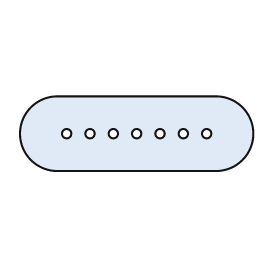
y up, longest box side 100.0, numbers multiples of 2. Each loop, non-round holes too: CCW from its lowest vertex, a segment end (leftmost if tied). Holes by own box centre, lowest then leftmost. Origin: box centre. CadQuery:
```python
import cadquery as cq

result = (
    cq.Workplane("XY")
    .moveTo(-34.0, -16.0)
    .lineTo(34.0, -16.0)
    .threePointArc((50.0, 0.0), (34.0, 16.0))
    .lineTo(-34.0, 16.0)
    .threePointArc((-50.0, 0.0), (-34.0, -16.0))
    .close()
    .moveTo(-30.0, 0.0)
    .circle(2.0)
    .moveTo(-20.0, 0.0)
    .circle(2.0)
    .moveTo(-10.0, 0.0)
    .circle(2.0)
    .moveTo(0.0, 0.0)
    .circle(2.0)
    .moveTo(10.0, 0.0)
    .circle(2.0)
    .moveTo(20.0, 0.0)
    .circle(2.0)
    .moveTo(30.0, 0.0)
    .circle(2.0)
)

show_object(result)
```